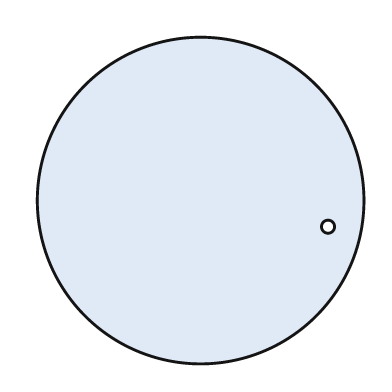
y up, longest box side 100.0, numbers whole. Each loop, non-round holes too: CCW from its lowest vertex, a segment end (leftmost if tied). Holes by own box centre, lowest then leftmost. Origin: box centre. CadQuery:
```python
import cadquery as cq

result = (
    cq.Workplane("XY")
    .moveTo(0.0, 0.0)
    .circle(50.0)
    .moveTo(39.0, -8.0)
    .circle(2.0)
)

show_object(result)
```